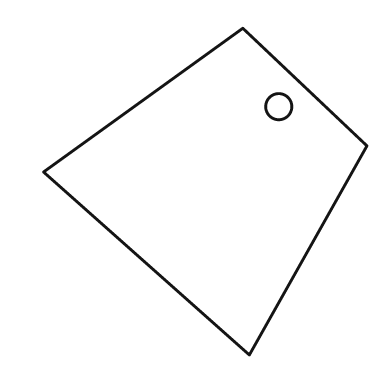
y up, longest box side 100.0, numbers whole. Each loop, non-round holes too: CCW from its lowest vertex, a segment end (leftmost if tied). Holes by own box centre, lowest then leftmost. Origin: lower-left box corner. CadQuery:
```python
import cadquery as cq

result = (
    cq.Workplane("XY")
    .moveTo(63.0, 0.0)
    .lineTo(99.0, 64.0)
    .lineTo(61.0, 100.0)
    .lineTo(0.0, 56.0)
    .close()
    .moveTo(72.0, 76.0)
    .circle(4.0)
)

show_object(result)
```